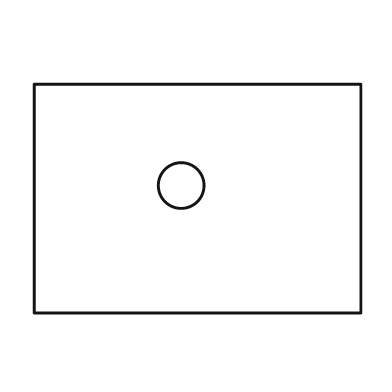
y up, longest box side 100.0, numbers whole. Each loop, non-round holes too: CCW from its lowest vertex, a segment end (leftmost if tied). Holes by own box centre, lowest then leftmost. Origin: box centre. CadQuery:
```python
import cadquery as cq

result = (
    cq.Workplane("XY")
    .moveTo(-50.0, -35.0)
    .lineTo(50.0, -35.0)
    .lineTo(50.0, 35.0)
    .lineTo(-50.0, 35.0)
    .close()
    .moveTo(-5.0, 4.0)
    .circle(7.0)
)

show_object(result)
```